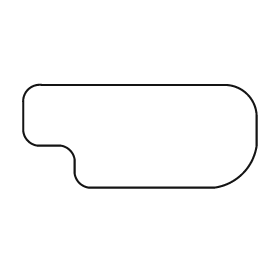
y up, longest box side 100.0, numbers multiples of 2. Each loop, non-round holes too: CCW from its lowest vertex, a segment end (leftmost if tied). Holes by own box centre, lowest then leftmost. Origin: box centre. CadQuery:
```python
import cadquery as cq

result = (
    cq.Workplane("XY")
    .moveTo(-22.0, -22.0)
    .lineTo(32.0, -22.0)
    .threePointArc((44.0, -16.0), (50.0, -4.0))
    .lineTo(50.0, 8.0)
    .threePointArc((46.0, 18.0), (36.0, 22.0))
    .lineTo(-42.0, 22.0)
    .threePointArc((-48.0, 20.0), (-50.0, 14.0))
    .lineTo(-50.0, 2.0)
    .threePointArc((-48.0, -2.0), (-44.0, -4.0))
    .lineTo(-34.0, -4.0)
    .threePointArc((-30.0, -6.0), (-28.0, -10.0))
    .lineTo(-28.0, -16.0)
    .threePointArc((-26.0, -20.0), (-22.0, -22.0))
    .close()
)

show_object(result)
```